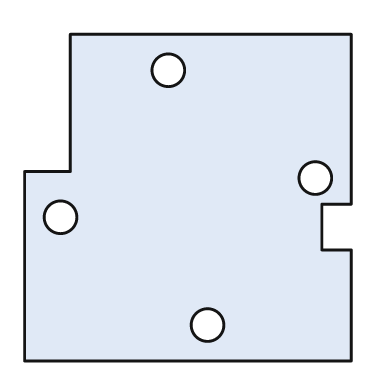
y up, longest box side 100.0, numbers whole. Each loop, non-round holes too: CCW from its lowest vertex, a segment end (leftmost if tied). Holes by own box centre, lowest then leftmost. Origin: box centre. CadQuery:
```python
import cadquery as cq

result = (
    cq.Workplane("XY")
    .moveTo(-50.0, -50.0)
    .lineTo(50.0, -50.0)
    .lineTo(50.0, -16.0)
    .lineTo(41.0, -16.0)
    .lineTo(41.0, -2.0)
    .lineTo(50.0, -2.0)
    .lineTo(50.0, 50.0)
    .lineTo(-36.0, 50.0)
    .lineTo(-36.0, 8.0)
    .lineTo(-50.0, 8.0)
    .close()
    .moveTo(6.0, -39.0)
    .circle(5.0)
    .moveTo(-39.0, -6.0)
    .circle(5.0)
    .moveTo(39.0, 6.0)
    .circle(5.0)
    .moveTo(-6.0, 39.0)
    .circle(5.0)
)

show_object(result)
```